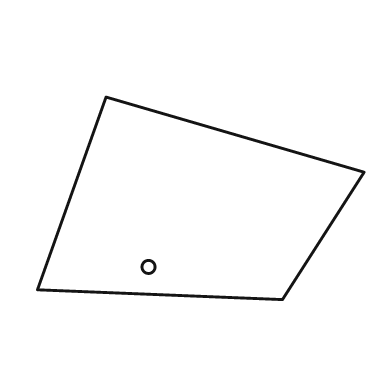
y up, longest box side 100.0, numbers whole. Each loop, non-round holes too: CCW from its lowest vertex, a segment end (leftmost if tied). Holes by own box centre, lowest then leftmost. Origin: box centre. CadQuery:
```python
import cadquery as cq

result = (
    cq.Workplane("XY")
    .moveTo(25.0, -31.0)
    .lineTo(50.0, 8.0)
    .lineTo(-29.0, 31.0)
    .lineTo(-50.0, -28.0)
    .close()
    .moveTo(-16.0, -21.0)
    .circle(2.0)
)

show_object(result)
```